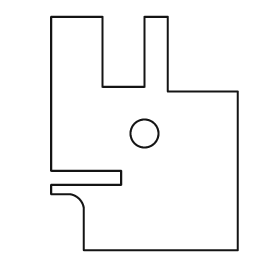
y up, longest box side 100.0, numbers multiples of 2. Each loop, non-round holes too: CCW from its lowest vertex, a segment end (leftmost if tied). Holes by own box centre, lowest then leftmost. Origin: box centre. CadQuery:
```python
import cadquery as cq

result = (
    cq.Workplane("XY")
    .moveTo(-26.0, -50.0)
    .lineTo(40.0, -50.0)
    .lineTo(40.0, 18.0)
    .lineTo(10.0, 18.0)
    .lineTo(10.0, 50.0)
    .lineTo(0.0, 50.0)
    .lineTo(0.0, 20.0)
    .lineTo(-18.0, 20.0)
    .lineTo(-18.0, 50.0)
    .lineTo(-40.0, 50.0)
    .lineTo(-40.0, -16.0)
    .lineTo(-10.0, -16.0)
    .lineTo(-10.0, -22.0)
    .lineTo(-40.0, -22.0)
    .lineTo(-40.0, -26.0)
    .lineTo(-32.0, -26.0)
    .threePointArc((-28.0, -28.0), (-26.0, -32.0))
    .close()
    .moveTo(0.0, 0.0)
    .circle(6.0)
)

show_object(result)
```